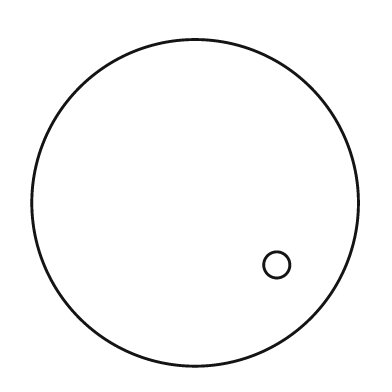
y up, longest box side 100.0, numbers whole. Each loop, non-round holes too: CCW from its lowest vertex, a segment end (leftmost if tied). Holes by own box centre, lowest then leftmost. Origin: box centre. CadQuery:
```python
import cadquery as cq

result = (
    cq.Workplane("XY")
    .moveTo(0.0, 0.0)
    .circle(50.0)
    .moveTo(25.0, -19.0)
    .circle(4.0)
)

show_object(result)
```